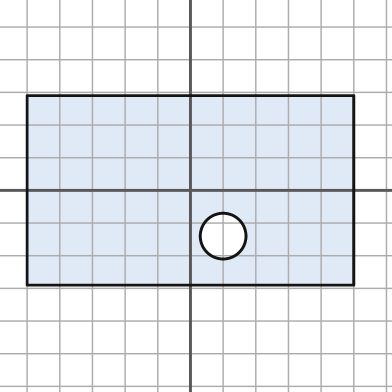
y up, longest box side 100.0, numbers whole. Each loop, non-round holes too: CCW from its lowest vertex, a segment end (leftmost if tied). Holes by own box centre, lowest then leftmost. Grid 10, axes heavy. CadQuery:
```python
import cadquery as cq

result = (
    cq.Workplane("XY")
    .moveTo(-50.0, -29.0)
    .lineTo(50.0, -29.0)
    .lineTo(50.0, 29.0)
    .lineTo(-50.0, 29.0)
    .close()
    .moveTo(10.0, -14.0)
    .circle(7.0)
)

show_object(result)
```